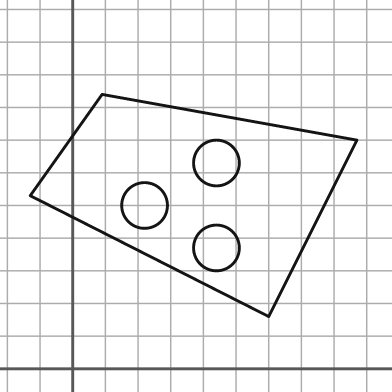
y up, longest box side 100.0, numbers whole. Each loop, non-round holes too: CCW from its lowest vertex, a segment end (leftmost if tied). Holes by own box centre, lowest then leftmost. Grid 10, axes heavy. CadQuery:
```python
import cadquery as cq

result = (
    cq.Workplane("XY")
    .moveTo(60.0, 16.0)
    .lineTo(87.0, 70.0)
    .lineTo(9.0, 84.0)
    .lineTo(-13.0, 53.0)
    .close()
    .moveTo(44.0, 37.0)
    .circle(7.0)
    .moveTo(22.0, 50.0)
    .circle(7.0)
    .moveTo(44.0, 63.0)
    .circle(7.0)
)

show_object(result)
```